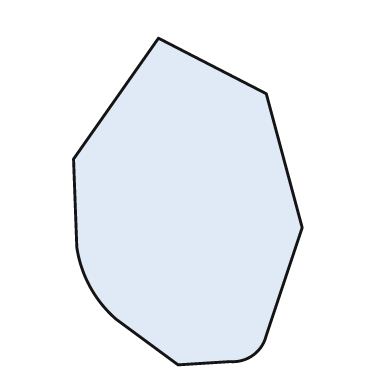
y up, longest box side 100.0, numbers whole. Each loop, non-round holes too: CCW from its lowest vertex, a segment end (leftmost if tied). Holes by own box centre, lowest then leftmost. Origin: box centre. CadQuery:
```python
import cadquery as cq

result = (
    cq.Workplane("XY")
    .moveTo(-3.0, -50.0)
    .lineTo(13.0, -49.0)
    .threePointArc((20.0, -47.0), (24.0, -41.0))
    .lineTo(35.0, -8.0)
    .lineTo(24.0, 33.0)
    .lineTo(-9.0, 50.0)
    .lineTo(-35.0, 13.0)
    .lineTo(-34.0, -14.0)
    .threePointArc((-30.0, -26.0), (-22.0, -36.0))
    .close()
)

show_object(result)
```